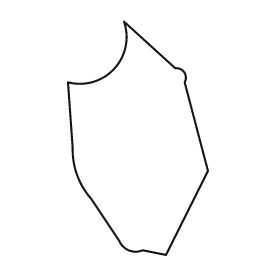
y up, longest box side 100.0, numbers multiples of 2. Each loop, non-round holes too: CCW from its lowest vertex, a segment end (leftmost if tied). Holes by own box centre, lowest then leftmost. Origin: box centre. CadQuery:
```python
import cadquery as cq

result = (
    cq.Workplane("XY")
    .moveTo(12.0, -50.0)
    .lineTo(30.0, -14.0)
    .lineTo(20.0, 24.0)
    .threePointArc((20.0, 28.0), (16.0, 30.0))
    .lineTo(-6.0, 50.0)
    .threePointArc((-10.0, 30.0), (-30.0, 24.0))
    .lineTo(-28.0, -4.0)
    .threePointArc((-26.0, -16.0), (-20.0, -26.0))
    .lineTo(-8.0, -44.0)
    .threePointArc((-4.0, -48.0), (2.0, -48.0))
    .close()
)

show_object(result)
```